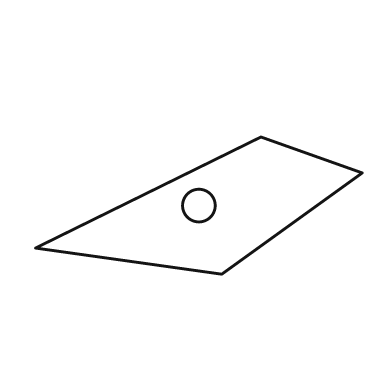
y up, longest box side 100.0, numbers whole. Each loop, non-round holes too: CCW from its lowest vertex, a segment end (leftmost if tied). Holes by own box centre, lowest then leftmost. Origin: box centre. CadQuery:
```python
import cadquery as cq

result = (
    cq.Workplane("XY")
    .moveTo(7.0, -21.0)
    .lineTo(50.0, 10.0)
    .lineTo(19.0, 21.0)
    .lineTo(-50.0, -13.0)
    .close()
    .moveTo(0.0, 0.0)
    .circle(5.0)
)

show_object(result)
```